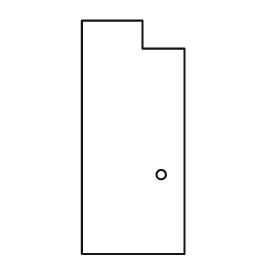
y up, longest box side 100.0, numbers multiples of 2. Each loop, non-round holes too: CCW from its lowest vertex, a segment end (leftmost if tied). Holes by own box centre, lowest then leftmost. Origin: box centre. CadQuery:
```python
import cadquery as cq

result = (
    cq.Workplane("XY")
    .moveTo(-22.0, -50.0)
    .lineTo(22.0, -50.0)
    .lineTo(22.0, 38.0)
    .lineTo(4.0, 38.0)
    .lineTo(4.0, 50.0)
    .lineTo(-22.0, 50.0)
    .close()
    .moveTo(12.0, -16.0)
    .circle(2.0)
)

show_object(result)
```